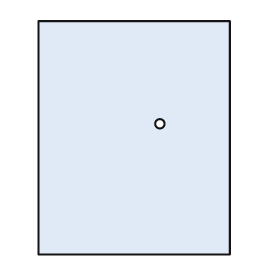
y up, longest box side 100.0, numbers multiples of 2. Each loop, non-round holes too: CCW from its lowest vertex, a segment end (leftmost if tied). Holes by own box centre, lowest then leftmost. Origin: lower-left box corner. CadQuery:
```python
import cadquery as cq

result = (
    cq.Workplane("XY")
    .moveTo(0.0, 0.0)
    .lineTo(82.0, 0.0)
    .lineTo(82.0, 100.0)
    .lineTo(0.0, 100.0)
    .close()
    .moveTo(52.0, 56.0)
    .circle(2.0)
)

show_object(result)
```